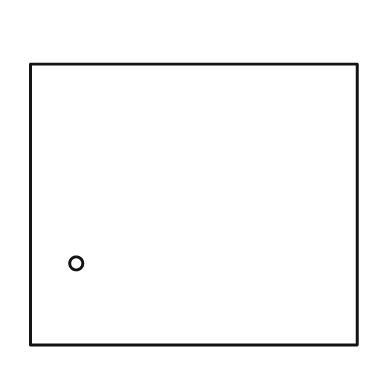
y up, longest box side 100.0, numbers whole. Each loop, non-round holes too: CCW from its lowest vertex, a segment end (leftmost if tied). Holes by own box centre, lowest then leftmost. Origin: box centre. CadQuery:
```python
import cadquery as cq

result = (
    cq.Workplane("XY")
    .moveTo(-50.0, -43.0)
    .lineTo(50.0, -43.0)
    .lineTo(50.0, 43.0)
    .lineTo(-50.0, 43.0)
    .close()
    .moveTo(-36.0, -18.0)
    .circle(2.0)
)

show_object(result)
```